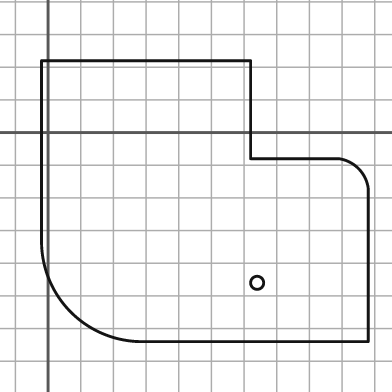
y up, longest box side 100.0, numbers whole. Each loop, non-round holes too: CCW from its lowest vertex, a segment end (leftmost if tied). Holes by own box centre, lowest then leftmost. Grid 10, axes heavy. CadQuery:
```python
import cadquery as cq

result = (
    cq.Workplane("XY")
    .moveTo(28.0, -64.0)
    .lineTo(98.0, -64.0)
    .lineTo(98.0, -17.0)
    .threePointArc((95.0, -11.0), (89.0, -8.0))
    .lineTo(62.0, -8.0)
    .lineTo(62.0, 22.0)
    .lineTo(-2.0, 22.0)
    .lineTo(-2.0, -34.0)
    .threePointArc((7.0, -55.0), (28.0, -64.0))
    .close()
    .moveTo(64.0, -46.0)
    .circle(2.0)
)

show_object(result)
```